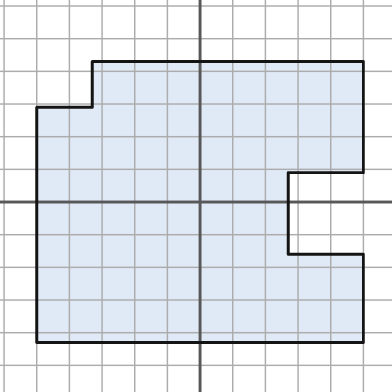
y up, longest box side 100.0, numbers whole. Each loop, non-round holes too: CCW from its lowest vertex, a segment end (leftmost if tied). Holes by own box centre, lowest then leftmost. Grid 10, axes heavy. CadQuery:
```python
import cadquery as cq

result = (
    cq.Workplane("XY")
    .moveTo(-50.0, -43.0)
    .lineTo(50.0, -43.0)
    .lineTo(50.0, -16.0)
    .lineTo(27.0, -16.0)
    .lineTo(27.0, 9.0)
    .lineTo(50.0, 9.0)
    .lineTo(50.0, 43.0)
    .lineTo(-33.0, 43.0)
    .lineTo(-33.0, 29.0)
    .lineTo(-50.0, 29.0)
    .close()
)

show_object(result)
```